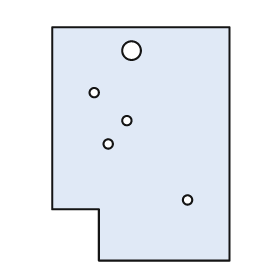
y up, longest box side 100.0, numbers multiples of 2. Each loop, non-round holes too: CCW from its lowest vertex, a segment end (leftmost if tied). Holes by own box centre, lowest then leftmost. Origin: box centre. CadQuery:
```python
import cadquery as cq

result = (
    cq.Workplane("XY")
    .moveTo(-18.0, -50.0)
    .lineTo(38.0, -50.0)
    .lineTo(38.0, 50.0)
    .lineTo(-38.0, 50.0)
    .lineTo(-38.0, -28.0)
    .lineTo(-18.0, -28.0)
    .close()
    .moveTo(20.0, -24.0)
    .circle(2.0)
    .moveTo(-14.0, 0.0)
    .circle(2.0)
    .moveTo(-6.0, 10.0)
    .circle(2.0)
    .moveTo(-20.0, 22.0)
    .circle(2.0)
    .moveTo(-4.0, 40.0)
    .circle(4.0)
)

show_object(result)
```